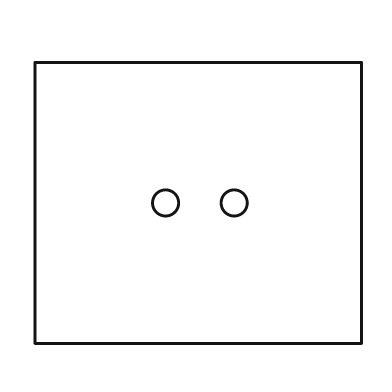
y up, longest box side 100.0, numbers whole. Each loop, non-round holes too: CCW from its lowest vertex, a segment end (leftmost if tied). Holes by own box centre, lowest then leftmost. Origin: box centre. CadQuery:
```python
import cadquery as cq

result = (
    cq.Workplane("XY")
    .moveTo(-50.0, -43.0)
    .lineTo(50.0, -43.0)
    .lineTo(50.0, 43.0)
    .lineTo(-50.0, 43.0)
    .close()
    .moveTo(-10.0, 0.0)
    .circle(4.0)
    .moveTo(11.0, 0.0)
    .circle(4.0)
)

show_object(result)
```